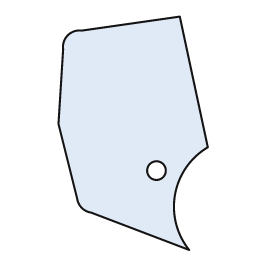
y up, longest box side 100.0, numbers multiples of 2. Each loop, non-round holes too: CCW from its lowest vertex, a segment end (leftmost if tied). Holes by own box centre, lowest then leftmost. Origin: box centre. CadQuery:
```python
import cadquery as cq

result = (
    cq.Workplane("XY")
    .moveTo(24.0, -50.0)
    .threePointArc((18.0, -26.0), (32.0, -6.0))
    .lineTo(20.0, 50.0)
    .lineTo(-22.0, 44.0)
    .threePointArc((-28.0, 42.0), (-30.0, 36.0))
    .lineTo(-32.0, 4.0)
    .lineTo(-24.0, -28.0)
    .threePointArc((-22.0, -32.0), (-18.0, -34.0))
    .close()
    .moveTo(10.0, -16.0)
    .circle(4.0)
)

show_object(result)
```